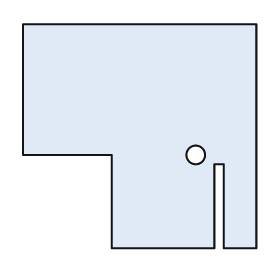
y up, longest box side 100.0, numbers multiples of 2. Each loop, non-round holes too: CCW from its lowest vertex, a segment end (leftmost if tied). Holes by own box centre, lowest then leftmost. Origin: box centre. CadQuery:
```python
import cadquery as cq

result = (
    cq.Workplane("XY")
    .moveTo(-12.0, -48.0)
    .lineTo(32.0, -48.0)
    .lineTo(32.0, -12.0)
    .lineTo(36.0, -12.0)
    .lineTo(36.0, -48.0)
    .lineTo(50.0, -48.0)
    .lineTo(50.0, 48.0)
    .lineTo(-50.0, 48.0)
    .lineTo(-50.0, -8.0)
    .lineTo(-12.0, -8.0)
    .close()
    .moveTo(24.0, -8.0)
    .circle(4.0)
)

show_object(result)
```